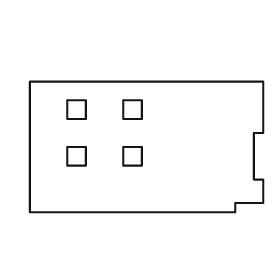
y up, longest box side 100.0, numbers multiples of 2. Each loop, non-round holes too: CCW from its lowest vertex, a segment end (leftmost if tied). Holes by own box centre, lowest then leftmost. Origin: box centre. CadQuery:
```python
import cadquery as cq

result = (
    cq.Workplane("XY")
    .moveTo(-50.0, -28.0)
    .lineTo(38.0, -28.0)
    .lineTo(38.0, -24.0)
    .lineTo(50.0, -24.0)
    .lineTo(50.0, -14.0)
    .lineTo(46.0, -14.0)
    .lineTo(46.0, 6.0)
    .lineTo(50.0, 6.0)
    .lineTo(50.0, 28.0)
    .lineTo(-50.0, 28.0)
    .close()
    .moveTo(-34.0, -8.0)
    .lineTo(-26.0, -8.0)
    .lineTo(-26.0, 0.0)
    .lineTo(-34.0, 0.0)
    .close()
    .moveTo(-10.0, -8.0)
    .lineTo(-2.0, -8.0)
    .lineTo(-2.0, 0.0)
    .lineTo(-10.0, 0.0)
    .close()
    .moveTo(-34.0, 12.0)
    .lineTo(-26.0, 12.0)
    .lineTo(-26.0, 20.0)
    .lineTo(-34.0, 20.0)
    .close()
    .moveTo(-10.0, 12.0)
    .lineTo(-2.0, 12.0)
    .lineTo(-2.0, 20.0)
    .lineTo(-10.0, 20.0)
    .close()
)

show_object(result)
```